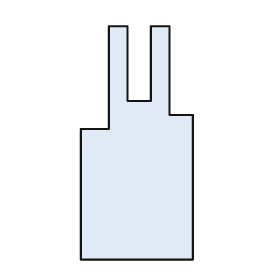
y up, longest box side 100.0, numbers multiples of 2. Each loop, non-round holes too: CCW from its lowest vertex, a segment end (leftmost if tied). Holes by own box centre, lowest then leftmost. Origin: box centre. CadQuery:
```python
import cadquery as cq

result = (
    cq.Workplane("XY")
    .moveTo(-24.0, -50.0)
    .lineTo(24.0, -50.0)
    .lineTo(24.0, 12.0)
    .lineTo(14.0, 12.0)
    .lineTo(14.0, 50.0)
    .lineTo(6.0, 50.0)
    .lineTo(6.0, 18.0)
    .lineTo(-4.0, 18.0)
    .lineTo(-4.0, 50.0)
    .lineTo(-12.0, 50.0)
    .lineTo(-12.0, 6.0)
    .lineTo(-24.0, 6.0)
    .close()
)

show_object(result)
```